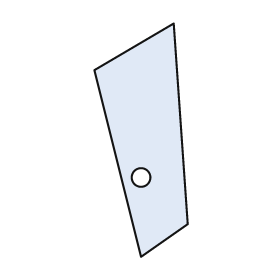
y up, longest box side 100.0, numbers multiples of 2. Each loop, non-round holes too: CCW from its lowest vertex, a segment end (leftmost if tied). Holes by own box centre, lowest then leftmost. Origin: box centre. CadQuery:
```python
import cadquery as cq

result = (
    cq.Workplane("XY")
    .moveTo(0.0, -50.0)
    .lineTo(20.0, -36.0)
    .lineTo(14.0, 50.0)
    .lineTo(-20.0, 30.0)
    .close()
    .moveTo(0.0, -16.0)
    .circle(4.0)
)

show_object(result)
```